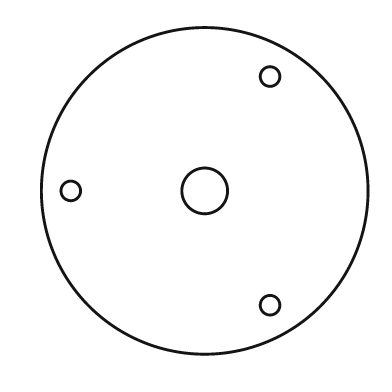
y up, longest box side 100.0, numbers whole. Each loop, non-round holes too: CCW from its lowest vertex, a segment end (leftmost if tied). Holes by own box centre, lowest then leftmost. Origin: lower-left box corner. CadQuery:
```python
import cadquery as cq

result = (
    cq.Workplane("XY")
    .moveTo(50.0, 50.0)
    .circle(50.0)
    .moveTo(70.0, 15.0)
    .circle(3.0)
    .moveTo(9.0, 50.0)
    .circle(3.0)
    .moveTo(50.0, 50.0)
    .circle(7.0)
    .moveTo(70.0, 85.0)
    .circle(3.0)
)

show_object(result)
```